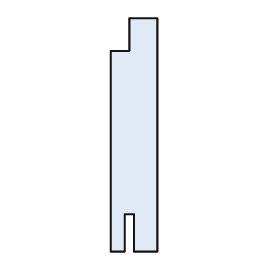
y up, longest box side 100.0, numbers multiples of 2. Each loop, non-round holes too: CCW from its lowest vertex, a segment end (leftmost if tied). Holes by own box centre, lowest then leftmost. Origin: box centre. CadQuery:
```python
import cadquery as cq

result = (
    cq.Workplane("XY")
    .moveTo(-10.0, -50.0)
    .lineTo(-4.0, -50.0)
    .lineTo(-4.0, -34.0)
    .lineTo(0.0, -34.0)
    .lineTo(0.0, -50.0)
    .lineTo(10.0, -50.0)
    .lineTo(10.0, 50.0)
    .lineTo(-2.0, 50.0)
    .lineTo(-2.0, 36.0)
    .lineTo(-10.0, 36.0)
    .close()
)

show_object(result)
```